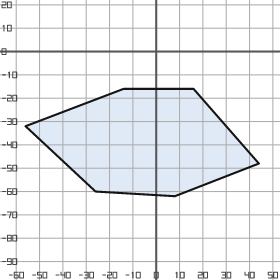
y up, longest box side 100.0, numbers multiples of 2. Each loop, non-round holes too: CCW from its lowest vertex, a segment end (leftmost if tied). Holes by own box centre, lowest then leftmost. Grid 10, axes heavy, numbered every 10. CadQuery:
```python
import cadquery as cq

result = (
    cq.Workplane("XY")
    .moveTo(8.0, -62.0)
    .lineTo(44.0, -48.0)
    .lineTo(16.0, -16.0)
    .lineTo(-14.0, -16.0)
    .lineTo(-56.0, -32.0)
    .lineTo(-26.0, -60.0)
    .close()
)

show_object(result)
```